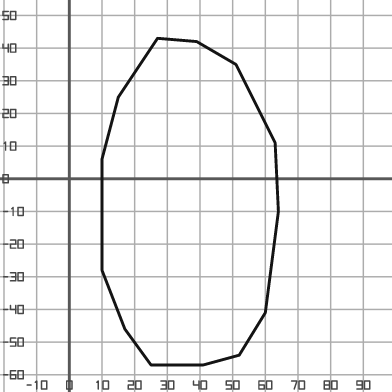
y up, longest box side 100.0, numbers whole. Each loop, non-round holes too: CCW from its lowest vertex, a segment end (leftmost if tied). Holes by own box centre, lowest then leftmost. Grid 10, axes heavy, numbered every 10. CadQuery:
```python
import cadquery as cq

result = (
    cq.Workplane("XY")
    .moveTo(25.0, -57.0)
    .lineTo(41.0, -57.0)
    .lineTo(52.0, -54.0)
    .lineTo(60.0, -41.0)
    .lineTo(64.0, -10.0)
    .lineTo(63.0, 11.0)
    .lineTo(51.0, 35.0)
    .lineTo(39.0, 42.0)
    .lineTo(27.0, 43.0)
    .lineTo(15.0, 25.0)
    .lineTo(10.0, 6.0)
    .lineTo(10.0, -28.0)
    .lineTo(17.0, -46.0)
    .close()
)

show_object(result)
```